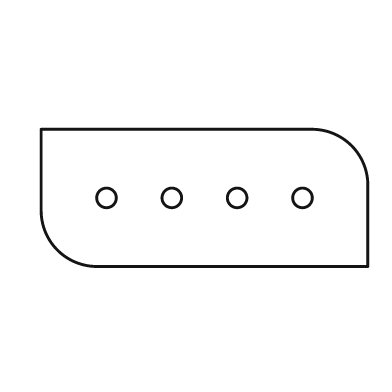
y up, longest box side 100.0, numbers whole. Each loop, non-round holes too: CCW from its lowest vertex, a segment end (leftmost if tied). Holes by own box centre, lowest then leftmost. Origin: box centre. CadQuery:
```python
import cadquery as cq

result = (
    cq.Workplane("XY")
    .moveTo(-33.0, -21.0)
    .lineTo(50.0, -21.0)
    .lineTo(50.0, 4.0)
    .threePointArc((45.0, 16.0), (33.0, 21.0))
    .lineTo(-50.0, 21.0)
    .lineTo(-50.0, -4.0)
    .threePointArc((-45.0, -16.0), (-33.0, -21.0))
    .close()
    .moveTo(-30.0, 0.0)
    .circle(3.0)
    .moveTo(-10.0, 0.0)
    .circle(3.0)
    .moveTo(10.0, 0.0)
    .circle(3.0)
    .moveTo(30.0, 0.0)
    .circle(3.0)
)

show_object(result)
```